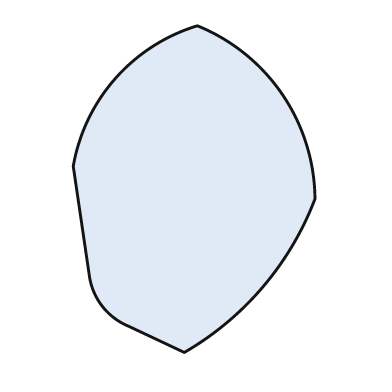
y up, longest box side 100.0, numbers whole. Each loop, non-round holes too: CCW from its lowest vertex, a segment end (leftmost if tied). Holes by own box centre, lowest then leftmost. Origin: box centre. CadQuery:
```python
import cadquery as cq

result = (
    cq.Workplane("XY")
    .moveTo(-3.0, -50.0)
    .threePointArc((21.0, -30.0), (37.0, -3.0))
    .threePointArc((27.0, 29.0), (1.0, 50.0))
    .threePointArc((-24.0, 34.0), (-37.0, 7.0))
    .lineTo(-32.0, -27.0)
    .threePointArc((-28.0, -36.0), (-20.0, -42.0))
    .close()
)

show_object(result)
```